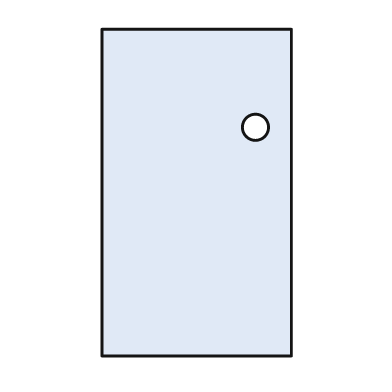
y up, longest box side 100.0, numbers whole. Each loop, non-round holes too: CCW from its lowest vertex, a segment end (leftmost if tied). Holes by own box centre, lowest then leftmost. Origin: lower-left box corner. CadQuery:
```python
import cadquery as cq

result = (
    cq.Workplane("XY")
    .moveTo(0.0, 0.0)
    .lineTo(58.0, 0.0)
    .lineTo(58.0, 100.0)
    .lineTo(0.0, 100.0)
    .close()
    .moveTo(47.0, 70.0)
    .circle(4.0)
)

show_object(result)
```